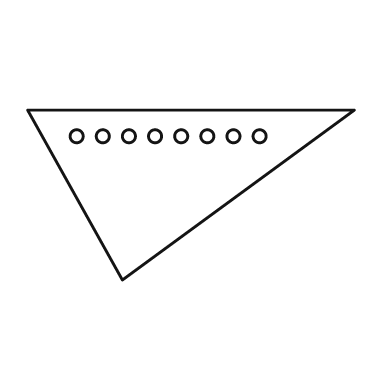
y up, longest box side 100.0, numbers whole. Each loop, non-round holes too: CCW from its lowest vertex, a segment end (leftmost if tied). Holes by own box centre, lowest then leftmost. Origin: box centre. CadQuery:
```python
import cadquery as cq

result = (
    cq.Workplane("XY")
    .moveTo(-21.0, -26.0)
    .lineTo(50.0, 26.0)
    .lineTo(-50.0, 26.0)
    .close()
    .moveTo(-35.0, 18.0)
    .circle(2.0)
    .moveTo(-27.0, 18.0)
    .circle(2.0)
    .moveTo(-19.0, 18.0)
    .circle(2.0)
    .moveTo(-11.0, 18.0)
    .circle(2.0)
    .moveTo(-3.0, 18.0)
    .circle(2.0)
    .moveTo(5.0, 18.0)
    .circle(2.0)
    .moveTo(13.0, 18.0)
    .circle(2.0)
    .moveTo(21.0, 18.0)
    .circle(2.0)
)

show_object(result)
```